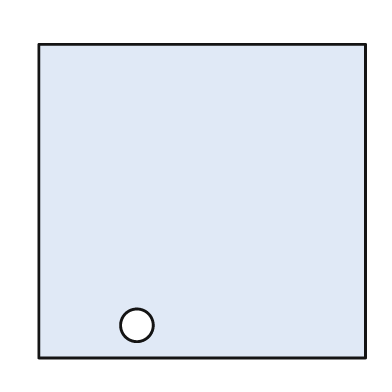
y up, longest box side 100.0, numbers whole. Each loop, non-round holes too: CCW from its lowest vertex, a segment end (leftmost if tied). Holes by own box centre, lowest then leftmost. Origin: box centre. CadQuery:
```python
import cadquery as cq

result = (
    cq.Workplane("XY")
    .moveTo(-50.0, -48.0)
    .lineTo(50.0, -48.0)
    .lineTo(50.0, 48.0)
    .lineTo(-50.0, 48.0)
    .close()
    .moveTo(-20.0, -38.0)
    .circle(5.0)
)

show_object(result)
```